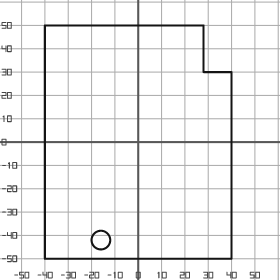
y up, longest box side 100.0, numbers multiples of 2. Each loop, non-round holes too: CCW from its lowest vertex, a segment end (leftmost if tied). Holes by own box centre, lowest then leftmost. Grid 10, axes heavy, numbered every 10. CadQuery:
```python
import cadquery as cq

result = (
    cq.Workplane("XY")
    .moveTo(-40.0, -50.0)
    .lineTo(40.0, -50.0)
    .lineTo(40.0, 30.0)
    .lineTo(28.0, 30.0)
    .lineTo(28.0, 50.0)
    .lineTo(-40.0, 50.0)
    .close()
    .moveTo(-16.0, -42.0)
    .circle(4.0)
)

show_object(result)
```